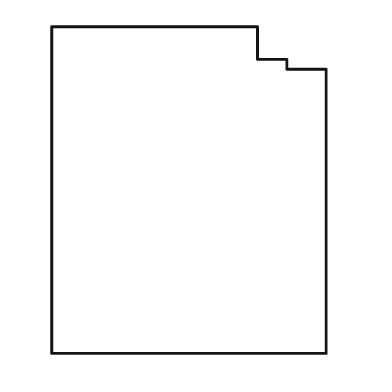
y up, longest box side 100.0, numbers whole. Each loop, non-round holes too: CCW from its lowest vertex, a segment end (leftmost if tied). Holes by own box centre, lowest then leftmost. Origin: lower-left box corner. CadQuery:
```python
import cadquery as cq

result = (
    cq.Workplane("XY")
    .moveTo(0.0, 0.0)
    .lineTo(84.0, 0.0)
    .lineTo(84.0, 87.0)
    .lineTo(72.0, 87.0)
    .lineTo(72.0, 90.0)
    .lineTo(63.0, 90.0)
    .lineTo(63.0, 100.0)
    .lineTo(0.0, 100.0)
    .close()
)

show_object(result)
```